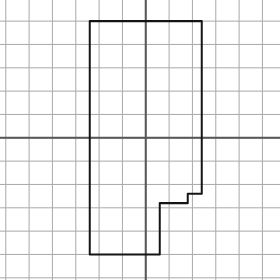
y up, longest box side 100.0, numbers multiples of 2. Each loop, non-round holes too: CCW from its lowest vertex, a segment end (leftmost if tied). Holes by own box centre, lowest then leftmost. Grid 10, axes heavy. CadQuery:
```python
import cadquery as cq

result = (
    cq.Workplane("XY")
    .moveTo(-24.0, -50.0)
    .lineTo(6.0, -50.0)
    .lineTo(6.0, -28.0)
    .lineTo(18.0, -28.0)
    .lineTo(18.0, -24.0)
    .lineTo(24.0, -24.0)
    .lineTo(24.0, 50.0)
    .lineTo(-24.0, 50.0)
    .close()
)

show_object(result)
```